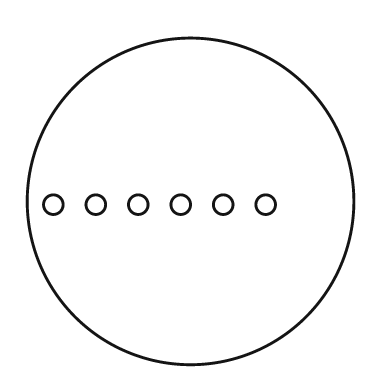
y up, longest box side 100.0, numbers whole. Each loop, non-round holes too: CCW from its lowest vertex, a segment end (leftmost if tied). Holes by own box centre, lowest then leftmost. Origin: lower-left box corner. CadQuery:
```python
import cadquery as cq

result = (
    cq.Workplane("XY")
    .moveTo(50.0, 50.0)
    .circle(50.0)
    .moveTo(8.0, 49.0)
    .circle(3.0)
    .moveTo(21.0, 49.0)
    .circle(3.0)
    .moveTo(34.0, 49.0)
    .circle(3.0)
    .moveTo(47.0, 49.0)
    .circle(3.0)
    .moveTo(60.0, 49.0)
    .circle(3.0)
    .moveTo(73.0, 49.0)
    .circle(3.0)
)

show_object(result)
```